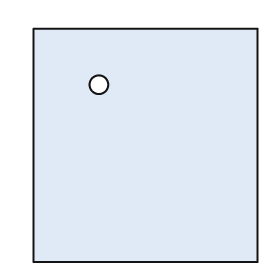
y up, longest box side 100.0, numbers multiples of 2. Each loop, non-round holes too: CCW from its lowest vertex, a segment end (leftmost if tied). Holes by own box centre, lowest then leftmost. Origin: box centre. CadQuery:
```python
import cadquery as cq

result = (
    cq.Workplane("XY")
    .moveTo(-48.0, -50.0)
    .lineTo(48.0, -50.0)
    .lineTo(48.0, 50.0)
    .lineTo(-48.0, 50.0)
    .close()
    .moveTo(-20.0, 26.0)
    .circle(4.0)
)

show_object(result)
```